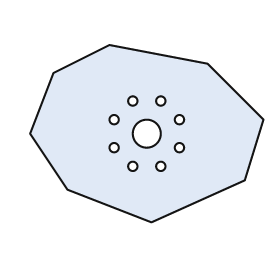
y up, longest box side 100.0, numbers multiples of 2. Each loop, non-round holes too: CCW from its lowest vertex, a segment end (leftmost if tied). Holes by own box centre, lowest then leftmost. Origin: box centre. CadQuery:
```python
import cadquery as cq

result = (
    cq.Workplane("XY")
    .moveTo(2.0, -38.0)
    .lineTo(42.0, -20.0)
    .lineTo(50.0, 6.0)
    .lineTo(26.0, 30.0)
    .lineTo(-16.0, 38.0)
    .lineTo(-40.0, 26.0)
    .lineTo(-50.0, 0.0)
    .lineTo(-34.0, -24.0)
    .close()
    .moveTo(-6.0, -14.0)
    .circle(2.0)
    .moveTo(6.0, -14.0)
    .circle(2.0)
    .moveTo(-14.0, -6.0)
    .circle(2.0)
    .moveTo(14.0, -6.0)
    .circle(2.0)
    .moveTo(0.0, 0.0)
    .circle(6.0)
    .moveTo(-14.0, 6.0)
    .circle(2.0)
    .moveTo(14.0, 6.0)
    .circle(2.0)
    .moveTo(-6.0, 14.0)
    .circle(2.0)
    .moveTo(6.0, 14.0)
    .circle(2.0)
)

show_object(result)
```